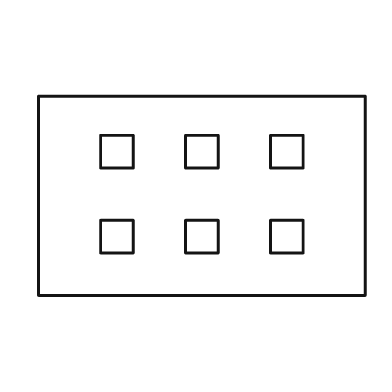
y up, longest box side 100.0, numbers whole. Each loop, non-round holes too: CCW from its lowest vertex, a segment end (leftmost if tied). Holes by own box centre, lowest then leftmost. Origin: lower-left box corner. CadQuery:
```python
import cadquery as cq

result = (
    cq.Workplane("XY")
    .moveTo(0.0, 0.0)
    .lineTo(100.0, 0.0)
    .lineTo(100.0, 61.0)
    .lineTo(0.0, 61.0)
    .close()
    .moveTo(19.0, 13.0)
    .lineTo(29.0, 13.0)
    .lineTo(29.0, 23.0)
    .lineTo(19.0, 23.0)
    .close()
    .moveTo(45.0, 13.0)
    .lineTo(55.0, 13.0)
    .lineTo(55.0, 23.0)
    .lineTo(45.0, 23.0)
    .close()
    .moveTo(71.0, 13.0)
    .lineTo(81.0, 13.0)
    .lineTo(81.0, 23.0)
    .lineTo(71.0, 23.0)
    .close()
    .moveTo(19.0, 39.0)
    .lineTo(29.0, 39.0)
    .lineTo(29.0, 49.0)
    .lineTo(19.0, 49.0)
    .close()
    .moveTo(45.0, 39.0)
    .lineTo(55.0, 39.0)
    .lineTo(55.0, 49.0)
    .lineTo(45.0, 49.0)
    .close()
    .moveTo(71.0, 39.0)
    .lineTo(81.0, 39.0)
    .lineTo(81.0, 49.0)
    .lineTo(71.0, 49.0)
    .close()
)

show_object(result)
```